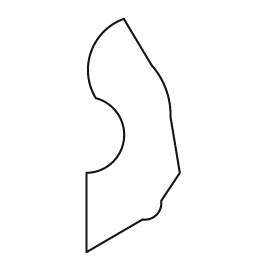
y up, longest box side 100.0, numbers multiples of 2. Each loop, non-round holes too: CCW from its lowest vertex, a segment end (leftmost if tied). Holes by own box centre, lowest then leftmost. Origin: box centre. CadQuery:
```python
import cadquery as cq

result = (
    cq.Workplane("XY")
    .moveTo(-20.0, -50.0)
    .lineTo(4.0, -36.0)
    .threePointArc((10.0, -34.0), (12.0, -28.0))
    .lineTo(20.0, -16.0)
    .lineTo(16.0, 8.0)
    .threePointArc((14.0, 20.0), (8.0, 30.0))
    .lineTo(-4.0, 50.0)
    .threePointArc((-18.0, 36.0), (-16.0, 16.0))
    .threePointArc((-4.0, -2.0), (-20.0, -16.0))
    .close()
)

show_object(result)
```